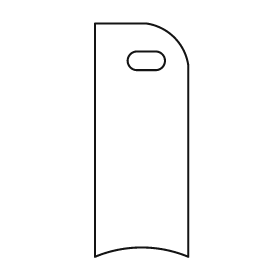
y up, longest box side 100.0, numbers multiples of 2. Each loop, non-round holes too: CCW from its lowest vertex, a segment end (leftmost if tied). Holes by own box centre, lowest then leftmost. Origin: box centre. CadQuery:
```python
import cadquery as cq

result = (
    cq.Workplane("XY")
    .moveTo(-20.0, -50.0)
    .threePointArc((0.0, -46.0), (20.0, -50.0))
    .lineTo(20.0, 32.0)
    .threePointArc((14.0, 44.0), (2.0, 50.0))
    .lineTo(-20.0, 50.0)
    .close()
    .moveTo(-2.0, 30.0)
    .lineTo(6.0, 30.0)
    .threePointArc((10.0, 34.0), (6.0, 38.0))
    .lineTo(-2.0, 38.0)
    .threePointArc((-6.0, 34.0), (-2.0, 30.0))
    .close()
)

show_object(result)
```